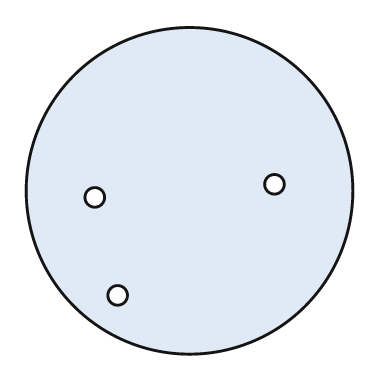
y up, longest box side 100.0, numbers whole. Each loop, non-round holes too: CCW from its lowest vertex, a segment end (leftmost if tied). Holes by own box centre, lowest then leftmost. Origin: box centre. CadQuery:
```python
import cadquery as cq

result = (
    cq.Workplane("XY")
    .moveTo(0.0, 0.0)
    .circle(50.0)
    .moveTo(-22.0, -32.0)
    .circle(3.0)
    .moveTo(-29.0, -2.0)
    .circle(3.0)
    .moveTo(26.0, 2.0)
    .circle(3.0)
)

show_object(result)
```